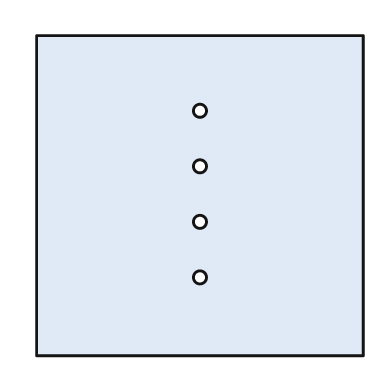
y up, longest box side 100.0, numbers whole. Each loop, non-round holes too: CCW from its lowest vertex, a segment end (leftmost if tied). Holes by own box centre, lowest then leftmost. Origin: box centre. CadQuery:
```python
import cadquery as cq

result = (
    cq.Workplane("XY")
    .moveTo(-50.0, -49.0)
    .lineTo(50.0, -49.0)
    .lineTo(50.0, 49.0)
    .lineTo(-50.0, 49.0)
    .close()
    .moveTo(0.0, -25.0)
    .circle(2.0)
    .moveTo(0.0, -8.0)
    .circle(2.0)
    .moveTo(0.0, 9.0)
    .circle(2.0)
    .moveTo(0.0, 26.0)
    .circle(2.0)
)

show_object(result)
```